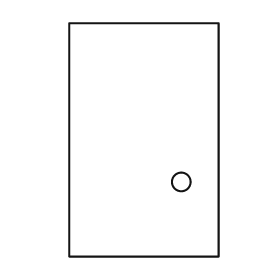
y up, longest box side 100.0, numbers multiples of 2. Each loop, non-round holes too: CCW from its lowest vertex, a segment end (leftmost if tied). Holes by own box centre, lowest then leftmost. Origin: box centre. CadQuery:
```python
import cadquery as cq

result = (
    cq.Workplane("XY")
    .moveTo(-32.0, -50.0)
    .lineTo(32.0, -50.0)
    .lineTo(32.0, 50.0)
    .lineTo(-32.0, 50.0)
    .close()
    .moveTo(16.0, -18.0)
    .circle(4.0)
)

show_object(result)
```